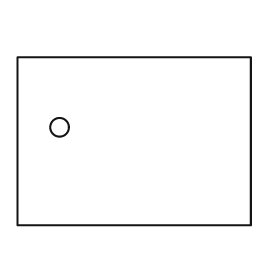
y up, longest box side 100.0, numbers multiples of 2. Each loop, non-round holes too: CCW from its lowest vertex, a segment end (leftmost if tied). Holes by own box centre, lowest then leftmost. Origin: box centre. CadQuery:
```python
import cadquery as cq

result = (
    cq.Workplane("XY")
    .moveTo(-50.0, -36.0)
    .lineTo(50.0, -36.0)
    .lineTo(50.0, 36.0)
    .lineTo(-50.0, 36.0)
    .close()
    .moveTo(-32.0, 6.0)
    .circle(4.0)
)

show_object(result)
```